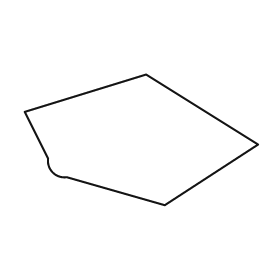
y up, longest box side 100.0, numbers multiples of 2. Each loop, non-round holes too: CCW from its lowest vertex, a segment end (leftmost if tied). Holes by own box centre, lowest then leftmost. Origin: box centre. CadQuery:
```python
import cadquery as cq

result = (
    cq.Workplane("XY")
    .moveTo(10.0, -28.0)
    .lineTo(50.0, -2.0)
    .lineTo(2.0, 28.0)
    .lineTo(-50.0, 12.0)
    .lineTo(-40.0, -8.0)
    .threePointArc((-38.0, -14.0), (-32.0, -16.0))
    .close()
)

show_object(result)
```